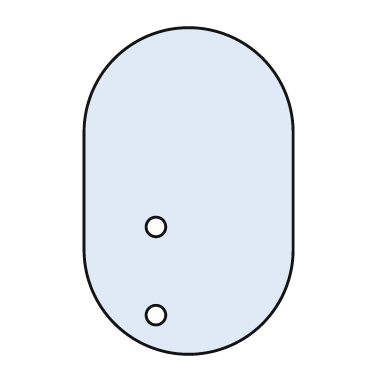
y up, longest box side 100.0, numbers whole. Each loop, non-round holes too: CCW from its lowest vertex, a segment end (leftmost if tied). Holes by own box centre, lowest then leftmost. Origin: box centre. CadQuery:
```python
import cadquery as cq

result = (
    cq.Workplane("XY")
    .moveTo(-32.0, -18.0)
    .threePointArc((0.0, -50.0), (32.0, -18.0))
    .lineTo(32.0, 18.0)
    .threePointArc((0.0, 50.0), (-32.0, 18.0))
    .close()
    .moveTo(-10.0, -38.0)
    .circle(3.0)
    .moveTo(-10.0, -11.0)
    .circle(3.0)
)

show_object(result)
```